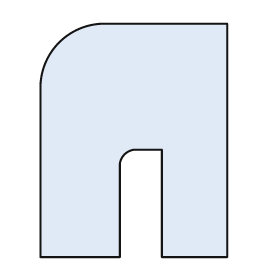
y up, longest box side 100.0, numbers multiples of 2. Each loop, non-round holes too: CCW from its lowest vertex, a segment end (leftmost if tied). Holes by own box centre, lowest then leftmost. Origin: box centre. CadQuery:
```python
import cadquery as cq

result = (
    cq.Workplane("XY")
    .moveTo(-40.0, -50.0)
    .lineTo(-6.0, -50.0)
    .lineTo(-6.0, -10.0)
    .threePointArc((-4.0, -6.0), (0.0, -4.0))
    .lineTo(12.0, -4.0)
    .lineTo(12.0, -50.0)
    .lineTo(40.0, -50.0)
    .lineTo(40.0, 50.0)
    .lineTo(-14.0, 50.0)
    .threePointArc((-32.0, 42.0), (-40.0, 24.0))
    .close()
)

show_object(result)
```